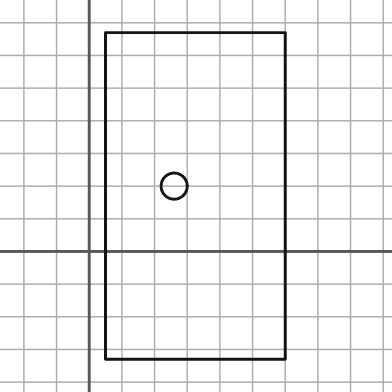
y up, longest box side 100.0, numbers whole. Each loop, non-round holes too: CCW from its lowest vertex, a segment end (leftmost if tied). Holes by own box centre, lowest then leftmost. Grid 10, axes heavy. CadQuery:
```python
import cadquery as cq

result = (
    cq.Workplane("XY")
    .moveTo(5.0, -33.0)
    .lineTo(60.0, -33.0)
    .lineTo(60.0, 67.0)
    .lineTo(5.0, 67.0)
    .close()
    .moveTo(26.0, 20.0)
    .circle(4.0)
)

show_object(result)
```